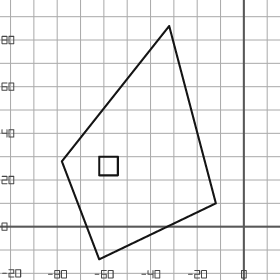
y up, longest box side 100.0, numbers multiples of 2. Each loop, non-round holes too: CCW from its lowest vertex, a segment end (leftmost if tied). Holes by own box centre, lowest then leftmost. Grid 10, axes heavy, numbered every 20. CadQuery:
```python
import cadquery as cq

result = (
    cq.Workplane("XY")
    .moveTo(-62.0, -14.0)
    .lineTo(-12.0, 10.0)
    .lineTo(-32.0, 86.0)
    .lineTo(-78.0, 28.0)
    .close()
    .moveTo(-62.0, 22.0)
    .lineTo(-54.0, 22.0)
    .lineTo(-54.0, 30.0)
    .lineTo(-62.0, 30.0)
    .close()
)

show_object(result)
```